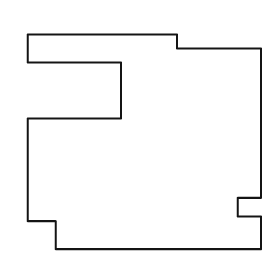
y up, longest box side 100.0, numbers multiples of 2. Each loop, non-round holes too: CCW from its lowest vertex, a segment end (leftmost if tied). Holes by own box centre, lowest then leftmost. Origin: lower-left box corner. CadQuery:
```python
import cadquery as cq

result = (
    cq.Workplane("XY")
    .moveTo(12.0, 0.0)
    .lineTo(100.0, 0.0)
    .lineTo(100.0, 14.0)
    .lineTo(90.0, 14.0)
    .lineTo(90.0, 22.0)
    .lineTo(100.0, 22.0)
    .lineTo(100.0, 86.0)
    .lineTo(64.0, 86.0)
    .lineTo(64.0, 92.0)
    .lineTo(0.0, 92.0)
    .lineTo(0.0, 80.0)
    .lineTo(40.0, 80.0)
    .lineTo(40.0, 56.0)
    .lineTo(0.0, 56.0)
    .lineTo(0.0, 12.0)
    .lineTo(12.0, 12.0)
    .close()
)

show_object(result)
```